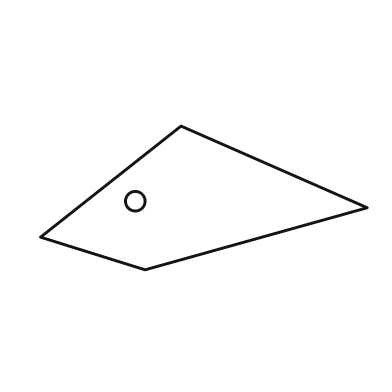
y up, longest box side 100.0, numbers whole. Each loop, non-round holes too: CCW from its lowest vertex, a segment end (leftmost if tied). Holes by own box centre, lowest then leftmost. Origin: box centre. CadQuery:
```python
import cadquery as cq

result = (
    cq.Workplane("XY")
    .moveTo(-18.0, -22.0)
    .lineTo(50.0, -3.0)
    .lineTo(-7.0, 22.0)
    .lineTo(-50.0, -12.0)
    .close()
    .moveTo(-21.0, -1.0)
    .circle(3.0)
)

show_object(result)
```